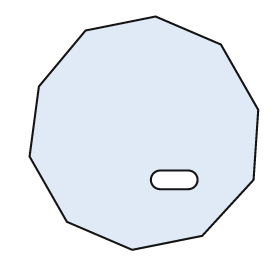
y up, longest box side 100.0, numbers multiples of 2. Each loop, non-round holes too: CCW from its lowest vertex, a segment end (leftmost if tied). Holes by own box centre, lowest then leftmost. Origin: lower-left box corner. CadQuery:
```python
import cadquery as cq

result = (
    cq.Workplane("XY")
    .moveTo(44.0, 0.0)
    .lineTo(74.0, 6.0)
    .lineTo(96.0, 30.0)
    .lineTo(98.0, 60.0)
    .lineTo(82.0, 88.0)
    .lineTo(54.0, 100.0)
    .lineTo(24.0, 94.0)
    .lineTo(4.0, 70.0)
    .lineTo(0.0, 40.0)
    .lineTo(16.0, 12.0)
    .close()
    .moveTo(56.0, 26.0)
    .lineTo(68.0, 26.0)
    .threePointArc((72.0, 30.0), (68.0, 34.0))
    .lineTo(56.0, 34.0)
    .threePointArc((52.0, 30.0), (56.0, 26.0))
    .close()
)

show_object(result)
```